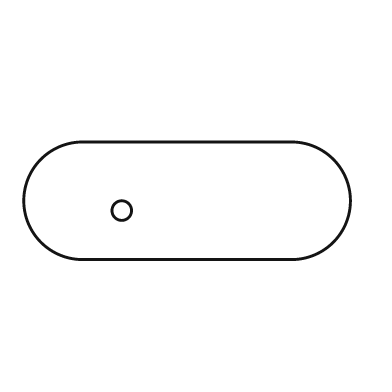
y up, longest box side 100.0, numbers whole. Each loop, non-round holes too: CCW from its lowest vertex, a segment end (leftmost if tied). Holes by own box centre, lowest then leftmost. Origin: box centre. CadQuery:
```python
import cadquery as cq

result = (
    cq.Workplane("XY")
    .moveTo(-32.0, -18.0)
    .lineTo(32.0, -18.0)
    .threePointArc((50.0, 0.0), (32.0, 18.0))
    .lineTo(-32.0, 18.0)
    .threePointArc((-50.0, 0.0), (-32.0, -18.0))
    .close()
    .moveTo(-20.0, -3.0)
    .circle(3.0)
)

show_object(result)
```